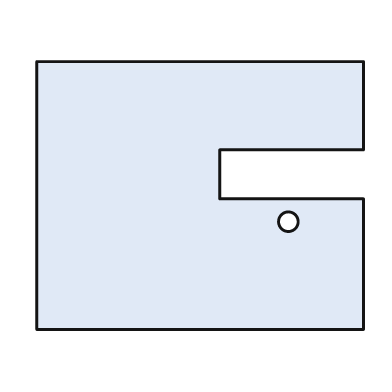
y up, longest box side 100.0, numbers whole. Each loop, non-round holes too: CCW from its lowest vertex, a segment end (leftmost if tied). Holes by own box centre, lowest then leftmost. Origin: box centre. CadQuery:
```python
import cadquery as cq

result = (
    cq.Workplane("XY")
    .moveTo(-50.0, -41.0)
    .lineTo(50.0, -41.0)
    .lineTo(50.0, -1.0)
    .lineTo(6.0, -1.0)
    .lineTo(6.0, 14.0)
    .lineTo(50.0, 14.0)
    .lineTo(50.0, 41.0)
    .lineTo(-50.0, 41.0)
    .close()
    .moveTo(27.0, -8.0)
    .circle(3.0)
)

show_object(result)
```